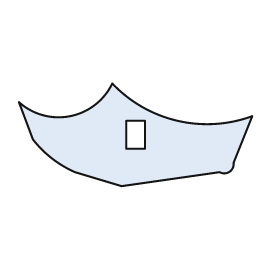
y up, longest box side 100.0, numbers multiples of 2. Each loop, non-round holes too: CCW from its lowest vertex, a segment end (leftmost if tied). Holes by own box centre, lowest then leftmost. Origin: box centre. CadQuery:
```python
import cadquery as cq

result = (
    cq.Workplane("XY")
    .moveTo(-6.0, -22.0)
    .lineTo(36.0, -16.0)
    .threePointArc((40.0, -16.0), (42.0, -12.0))
    .lineTo(50.0, 8.0)
    .threePointArc((18.0, 6.0), (-10.0, 22.0))
    .threePointArc((-28.0, 8.0), (-50.0, 14.0))
    .lineTo(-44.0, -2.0)
    .threePointArc((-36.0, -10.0), (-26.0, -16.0))
    .close()
    .moveTo(-4.0, -6.0)
    .lineTo(4.0, -6.0)
    .lineTo(4.0, 6.0)
    .lineTo(-4.0, 6.0)
    .close()
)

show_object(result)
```